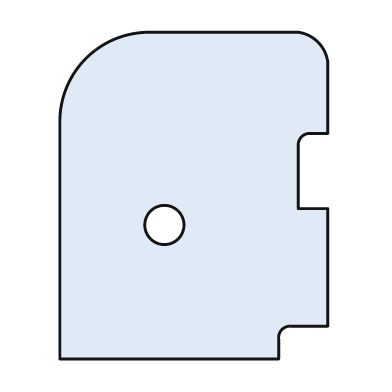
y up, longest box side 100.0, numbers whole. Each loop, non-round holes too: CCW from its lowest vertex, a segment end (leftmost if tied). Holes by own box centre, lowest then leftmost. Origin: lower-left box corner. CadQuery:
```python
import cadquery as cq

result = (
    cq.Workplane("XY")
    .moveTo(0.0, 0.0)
    .lineTo(67.0, 0.0)
    .lineTo(67.0, 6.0)
    .threePointArc((68.0, 9.0), (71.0, 10.0))
    .lineTo(82.0, 10.0)
    .lineTo(82.0, 46.0)
    .lineTo(73.0, 46.0)
    .lineTo(73.0, 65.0)
    .threePointArc((74.0, 68.0), (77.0, 69.0))
    .lineTo(82.0, 69.0)
    .lineTo(82.0, 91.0)
    .threePointArc((79.0, 97.0), (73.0, 100.0))
    .lineTo(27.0, 100.0)
    .threePointArc((8.0, 92.0), (0.0, 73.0))
    .close()
    .moveTo(32.0, 41.0)
    .circle(6.0)
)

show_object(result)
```